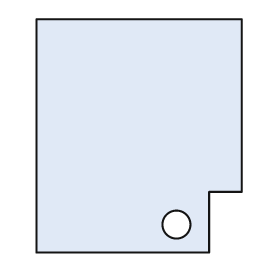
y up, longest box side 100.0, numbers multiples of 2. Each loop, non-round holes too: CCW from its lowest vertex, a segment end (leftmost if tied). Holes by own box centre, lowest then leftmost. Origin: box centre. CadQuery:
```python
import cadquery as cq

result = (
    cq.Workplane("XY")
    .moveTo(-44.0, -50.0)
    .lineTo(30.0, -50.0)
    .lineTo(30.0, -24.0)
    .lineTo(44.0, -24.0)
    .lineTo(44.0, 50.0)
    .lineTo(-44.0, 50.0)
    .close()
    .moveTo(16.0, -38.0)
    .circle(6.0)
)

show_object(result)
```